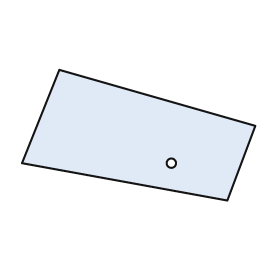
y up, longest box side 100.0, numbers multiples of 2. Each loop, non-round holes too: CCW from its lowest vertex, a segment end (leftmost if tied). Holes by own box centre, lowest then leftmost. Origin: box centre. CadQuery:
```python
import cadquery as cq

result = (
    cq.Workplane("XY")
    .moveTo(38.0, -28.0)
    .lineTo(50.0, 4.0)
    .lineTo(-34.0, 28.0)
    .lineTo(-50.0, -12.0)
    .close()
    .moveTo(14.0, -12.0)
    .circle(2.0)
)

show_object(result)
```